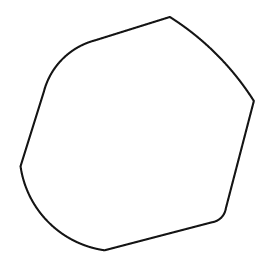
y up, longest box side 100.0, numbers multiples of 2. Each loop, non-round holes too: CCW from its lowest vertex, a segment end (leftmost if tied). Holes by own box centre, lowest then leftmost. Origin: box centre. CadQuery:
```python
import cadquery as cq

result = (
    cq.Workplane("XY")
    .moveTo(-14.0, -50.0)
    .lineTo(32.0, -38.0)
    .threePointArc((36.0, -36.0), (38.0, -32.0))
    .lineTo(50.0, 14.0)
    .threePointArc((34.0, 34.0), (14.0, 50.0))
    .lineTo(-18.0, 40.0)
    .threePointArc((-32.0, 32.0), (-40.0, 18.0))
    .lineTo(-50.0, -14.0)
    .threePointArc((-38.0, -38.0), (-14.0, -50.0))
    .close()
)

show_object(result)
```